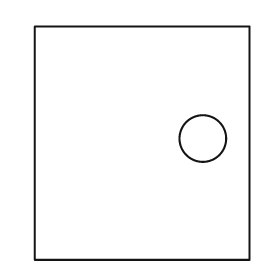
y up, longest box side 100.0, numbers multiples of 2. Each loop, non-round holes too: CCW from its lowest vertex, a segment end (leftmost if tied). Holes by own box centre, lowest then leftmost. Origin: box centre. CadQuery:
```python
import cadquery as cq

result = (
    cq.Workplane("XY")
    .moveTo(-46.0, -50.0)
    .lineTo(46.0, -50.0)
    .lineTo(46.0, 50.0)
    .lineTo(-46.0, 50.0)
    .close()
    .moveTo(26.0, 2.0)
    .circle(10.0)
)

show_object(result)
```